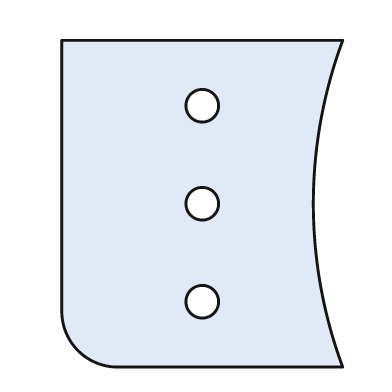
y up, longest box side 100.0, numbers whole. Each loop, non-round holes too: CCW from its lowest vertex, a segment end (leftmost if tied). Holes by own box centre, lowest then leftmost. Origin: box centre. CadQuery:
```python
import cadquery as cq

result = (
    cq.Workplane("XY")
    .moveTo(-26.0, -50.0)
    .lineTo(43.0, -50.0)
    .threePointArc((34.0, 0.0), (43.0, 50.0))
    .lineTo(-43.0, 50.0)
    .lineTo(-43.0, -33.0)
    .threePointArc((-38.0, -45.0), (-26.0, -50.0))
    .close()
    .moveTo(0.0, -30.0)
    .circle(5.0)
    .moveTo(0.0, 0.0)
    .circle(5.0)
    .moveTo(0.0, 30.0)
    .circle(5.0)
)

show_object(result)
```